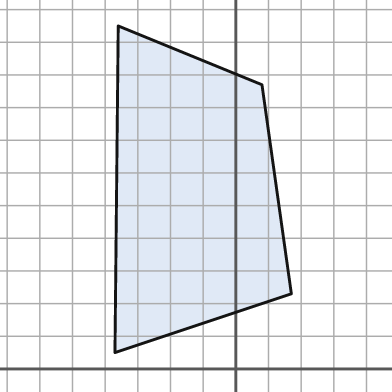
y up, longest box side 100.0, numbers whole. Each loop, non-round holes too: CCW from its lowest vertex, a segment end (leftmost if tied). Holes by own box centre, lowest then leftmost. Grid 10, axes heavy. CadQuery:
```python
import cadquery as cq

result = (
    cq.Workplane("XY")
    .moveTo(-37.0, 5.0)
    .lineTo(17.0, 23.0)
    .lineTo(8.0, 87.0)
    .lineTo(-36.0, 105.0)
    .close()
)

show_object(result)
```